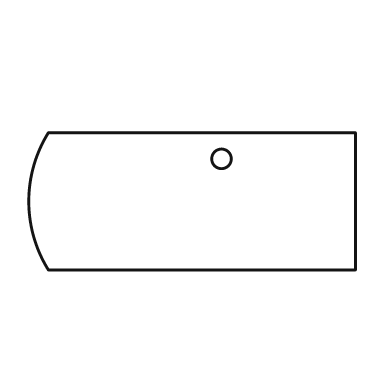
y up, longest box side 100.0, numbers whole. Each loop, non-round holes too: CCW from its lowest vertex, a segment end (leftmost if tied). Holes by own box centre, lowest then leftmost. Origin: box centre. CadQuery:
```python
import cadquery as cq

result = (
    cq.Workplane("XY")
    .moveTo(-44.0, -21.0)
    .lineTo(50.0, -21.0)
    .lineTo(50.0, 21.0)
    .lineTo(-44.0, 21.0)
    .threePointArc((-50.0, 0.0), (-44.0, -21.0))
    .close()
    .moveTo(9.0, 13.0)
    .circle(3.0)
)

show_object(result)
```